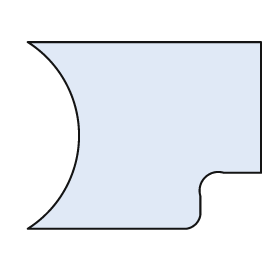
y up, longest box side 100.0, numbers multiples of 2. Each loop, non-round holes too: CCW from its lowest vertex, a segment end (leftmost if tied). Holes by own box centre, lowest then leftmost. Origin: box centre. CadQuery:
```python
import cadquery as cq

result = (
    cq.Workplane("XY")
    .moveTo(-50.0, -40.0)
    .lineTo(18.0, -40.0)
    .threePointArc((22.0, -38.0), (24.0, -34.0))
    .lineTo(24.0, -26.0)
    .threePointArc((26.0, -18.0), (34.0, -16.0))
    .lineTo(50.0, -16.0)
    .lineTo(50.0, 40.0)
    .lineTo(-50.0, 40.0)
    .threePointArc((-28.0, 0.0), (-50.0, -40.0))
    .close()
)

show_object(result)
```